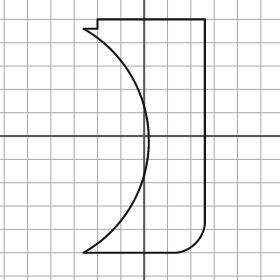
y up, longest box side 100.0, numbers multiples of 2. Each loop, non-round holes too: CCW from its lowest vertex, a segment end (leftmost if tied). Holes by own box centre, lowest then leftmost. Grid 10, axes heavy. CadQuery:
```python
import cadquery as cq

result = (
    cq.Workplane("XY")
    .moveTo(-26.0, -50.0)
    .lineTo(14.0, -50.0)
    .threePointArc((22.0, -46.0), (26.0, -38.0))
    .lineTo(26.0, 50.0)
    .lineTo(-20.0, 50.0)
    .lineTo(-20.0, 46.0)
    .lineTo(-26.0, 46.0)
    .threePointArc((2.0, -2.0), (-26.0, -50.0))
    .close()
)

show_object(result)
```